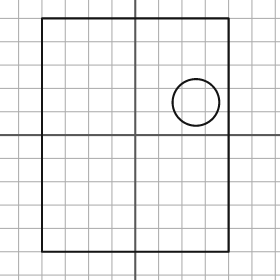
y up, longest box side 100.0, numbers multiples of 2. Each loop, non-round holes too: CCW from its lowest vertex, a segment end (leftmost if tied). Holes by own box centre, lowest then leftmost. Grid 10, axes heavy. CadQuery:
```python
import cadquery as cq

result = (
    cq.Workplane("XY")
    .moveTo(-40.0, -50.0)
    .lineTo(40.0, -50.0)
    .lineTo(40.0, 50.0)
    .lineTo(-40.0, 50.0)
    .close()
    .moveTo(26.0, 14.0)
    .circle(10.0)
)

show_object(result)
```